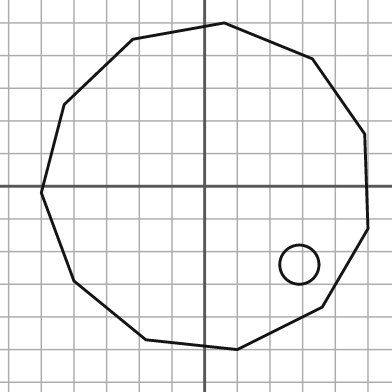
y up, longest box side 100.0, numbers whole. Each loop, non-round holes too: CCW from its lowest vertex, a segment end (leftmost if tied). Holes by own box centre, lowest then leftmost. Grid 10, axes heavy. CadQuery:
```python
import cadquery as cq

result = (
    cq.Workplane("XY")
    .moveTo(10.0, -50.0)
    .lineTo(36.0, -37.0)
    .lineTo(50.0, -13.0)
    .lineTo(49.0, 16.0)
    .lineTo(33.0, 39.0)
    .lineTo(6.0, 50.0)
    .lineTo(-22.0, 45.0)
    .lineTo(-43.0, 25.0)
    .lineTo(-50.0, -2.0)
    .lineTo(-40.0, -29.0)
    .lineTo(-18.0, -47.0)
    .close()
    .moveTo(29.0, -24.0)
    .circle(6.0)
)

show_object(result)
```